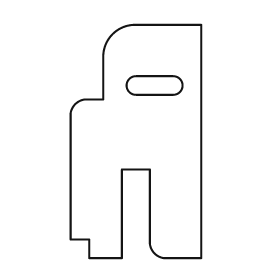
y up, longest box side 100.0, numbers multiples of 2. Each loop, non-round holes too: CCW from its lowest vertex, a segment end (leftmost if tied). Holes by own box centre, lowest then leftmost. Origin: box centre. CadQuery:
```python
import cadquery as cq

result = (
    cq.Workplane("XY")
    .moveTo(-20.0, -50.0)
    .lineTo(-6.0, -50.0)
    .lineTo(-6.0, -12.0)
    .lineTo(6.0, -12.0)
    .lineTo(6.0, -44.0)
    .threePointArc((8.0, -48.0), (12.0, -50.0))
    .lineTo(28.0, -50.0)
    .lineTo(28.0, 50.0)
    .lineTo(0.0, 50.0)
    .threePointArc((-10.0, 46.0), (-14.0, 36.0))
    .lineTo(-14.0, 18.0)
    .lineTo(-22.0, 18.0)
    .threePointArc((-26.0, 16.0), (-28.0, 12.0))
    .lineTo(-28.0, -42.0)
    .lineTo(-20.0, -42.0)
    .close()
    .moveTo(0.0, 20.0)
    .lineTo(16.0, 20.0)
    .threePointArc((20.0, 24.0), (16.0, 28.0))
    .lineTo(0.0, 28.0)
    .threePointArc((-4.0, 24.0), (0.0, 20.0))
    .close()
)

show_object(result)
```